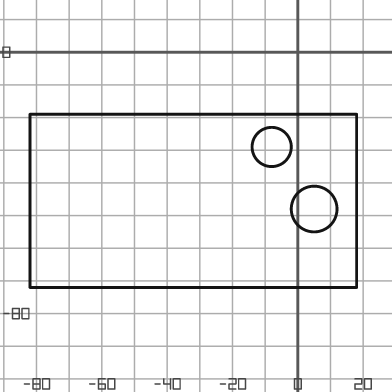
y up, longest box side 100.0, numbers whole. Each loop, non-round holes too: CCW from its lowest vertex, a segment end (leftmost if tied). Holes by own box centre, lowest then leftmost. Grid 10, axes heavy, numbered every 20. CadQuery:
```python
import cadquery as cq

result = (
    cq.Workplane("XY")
    .moveTo(-82.0, -72.0)
    .lineTo(18.0, -72.0)
    .lineTo(18.0, -19.0)
    .lineTo(-82.0, -19.0)
    .close()
    .moveTo(5.0, -48.0)
    .circle(7.0)
    .moveTo(-8.0, -29.0)
    .circle(6.0)
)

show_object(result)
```